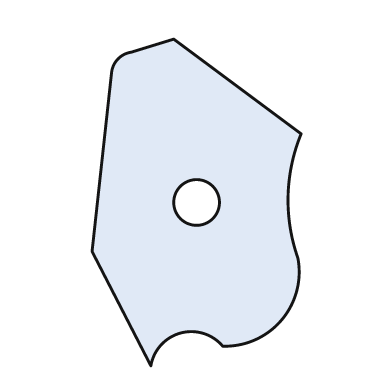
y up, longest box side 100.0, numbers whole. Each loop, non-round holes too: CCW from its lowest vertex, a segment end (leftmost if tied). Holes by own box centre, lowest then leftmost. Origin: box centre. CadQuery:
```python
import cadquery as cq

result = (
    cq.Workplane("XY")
    .moveTo(-14.0, -50.0)
    .threePointArc((-5.0, -40.0), (8.0, -44.0))
    .threePointArc((26.0, -36.0), (31.0, -17.0))
    .threePointArc((28.0, 2.0), (32.0, 21.0))
    .lineTo(-7.0, 50.0)
    .lineTo(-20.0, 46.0)
    .threePointArc((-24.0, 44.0), (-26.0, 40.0))
    .lineTo(-32.0, -15.0)
    .close()
    .moveTo(0.0, 0.0)
    .circle(7.0)
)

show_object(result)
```